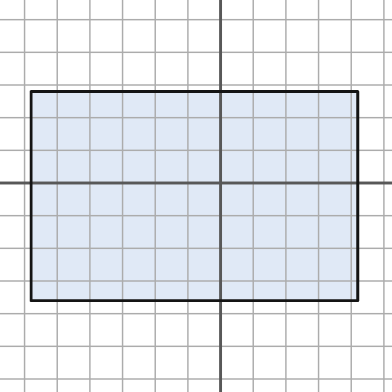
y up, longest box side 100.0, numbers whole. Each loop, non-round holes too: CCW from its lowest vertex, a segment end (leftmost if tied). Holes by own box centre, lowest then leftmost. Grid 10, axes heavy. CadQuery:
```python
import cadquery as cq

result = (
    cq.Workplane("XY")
    .moveTo(-58.0, -36.0)
    .lineTo(42.0, -36.0)
    .lineTo(42.0, 28.0)
    .lineTo(-58.0, 28.0)
    .close()
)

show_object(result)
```